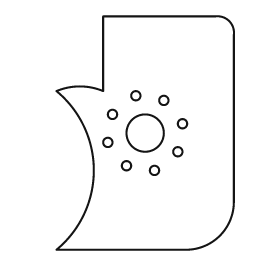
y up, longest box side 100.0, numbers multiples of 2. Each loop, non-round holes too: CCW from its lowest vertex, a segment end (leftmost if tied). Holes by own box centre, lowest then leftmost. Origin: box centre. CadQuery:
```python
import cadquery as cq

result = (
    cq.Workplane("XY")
    .moveTo(-38.0, -50.0)
    .lineTo(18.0, -50.0)
    .threePointArc((32.0, -44.0), (38.0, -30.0))
    .lineTo(38.0, 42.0)
    .threePointArc((36.0, 48.0), (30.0, 50.0))
    .lineTo(-18.0, 50.0)
    .lineTo(-18.0, 18.0)
    .threePointArc((-28.0, 20.0), (-38.0, 18.0))
    .threePointArc((-22.0, -16.0), (-38.0, -50.0))
    .close()
    .moveTo(4.0, -16.0)
    .circle(2.0)
    .moveTo(-8.0, -14.0)
    .circle(2.0)
    .moveTo(14.0, -8.0)
    .circle(2.0)
    .moveTo(-16.0, -4.0)
    .circle(2.0)
    .moveTo(0.0, 0.0)
    .circle(8.0)
    .moveTo(16.0, 4.0)
    .circle(2.0)
    .moveTo(-14.0, 8.0)
    .circle(2.0)
    .moveTo(8.0, 14.0)
    .circle(2.0)
    .moveTo(-4.0, 16.0)
    .circle(2.0)
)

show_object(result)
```